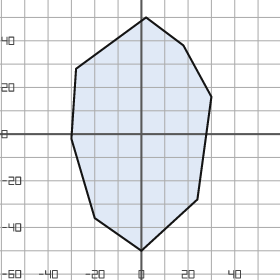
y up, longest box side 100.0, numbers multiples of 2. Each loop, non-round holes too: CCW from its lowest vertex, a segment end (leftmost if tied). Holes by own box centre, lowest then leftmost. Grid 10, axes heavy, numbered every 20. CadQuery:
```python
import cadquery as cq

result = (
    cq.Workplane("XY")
    .moveTo(0.0, -50.0)
    .lineTo(24.0, -28.0)
    .lineTo(30.0, 16.0)
    .lineTo(18.0, 38.0)
    .lineTo(2.0, 50.0)
    .lineTo(-28.0, 28.0)
    .lineTo(-30.0, -2.0)
    .lineTo(-20.0, -36.0)
    .close()
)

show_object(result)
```